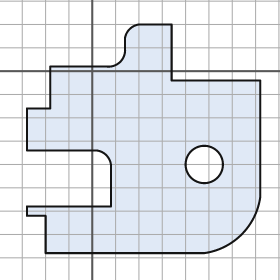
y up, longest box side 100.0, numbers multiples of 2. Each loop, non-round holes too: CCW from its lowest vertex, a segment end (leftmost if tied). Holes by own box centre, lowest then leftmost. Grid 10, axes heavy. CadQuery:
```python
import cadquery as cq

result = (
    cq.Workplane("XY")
    .moveTo(-20.0, -78.0)
    .lineTo(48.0, -78.0)
    .threePointArc((64.0, -70.0), (72.0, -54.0))
    .lineTo(72.0, -4.0)
    .lineTo(34.0, -4.0)
    .lineTo(34.0, 20.0)
    .lineTo(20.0, 20.0)
    .threePointArc((16.0, 18.0), (14.0, 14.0))
    .lineTo(14.0, 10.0)
    .threePointArc((12.0, 4.0), (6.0, 2.0))
    .lineTo(-18.0, 2.0)
    .lineTo(-18.0, -16.0)
    .lineTo(-28.0, -16.0)
    .lineTo(-28.0, -34.0)
    .lineTo(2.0, -34.0)
    .threePointArc((6.0, -36.0), (8.0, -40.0))
    .lineTo(8.0, -58.0)
    .lineTo(-28.0, -58.0)
    .lineTo(-28.0, -62.0)
    .lineTo(-20.0, -62.0)
    .close()
    .moveTo(48.0, -40.0)
    .circle(8.0)
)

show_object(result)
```